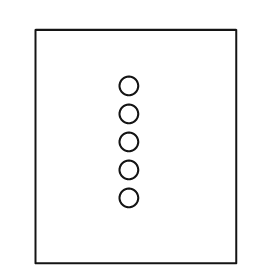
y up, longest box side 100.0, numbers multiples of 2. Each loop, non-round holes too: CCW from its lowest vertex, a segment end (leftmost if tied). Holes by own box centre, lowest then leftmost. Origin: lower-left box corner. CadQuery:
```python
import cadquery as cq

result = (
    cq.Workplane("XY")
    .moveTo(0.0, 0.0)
    .lineTo(86.0, 0.0)
    .lineTo(86.0, 100.0)
    .lineTo(0.0, 100.0)
    .close()
    .moveTo(40.0, 28.0)
    .circle(4.0)
    .moveTo(40.0, 40.0)
    .circle(4.0)
    .moveTo(40.0, 52.0)
    .circle(4.0)
    .moveTo(40.0, 64.0)
    .circle(4.0)
    .moveTo(40.0, 76.0)
    .circle(4.0)
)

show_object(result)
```